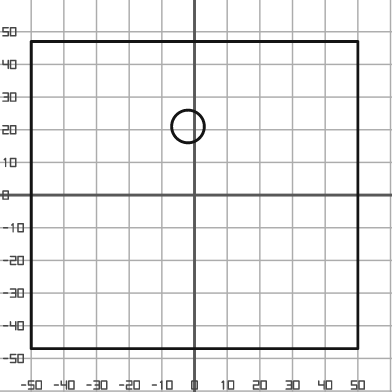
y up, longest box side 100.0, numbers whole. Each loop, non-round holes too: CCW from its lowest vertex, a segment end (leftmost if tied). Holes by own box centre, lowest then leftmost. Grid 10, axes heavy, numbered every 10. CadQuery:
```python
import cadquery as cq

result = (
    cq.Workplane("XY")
    .moveTo(-50.0, -47.0)
    .lineTo(50.0, -47.0)
    .lineTo(50.0, 47.0)
    .lineTo(-50.0, 47.0)
    .close()
    .moveTo(-2.0, 21.0)
    .circle(5.0)
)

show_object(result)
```